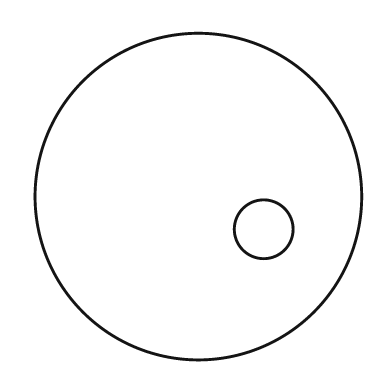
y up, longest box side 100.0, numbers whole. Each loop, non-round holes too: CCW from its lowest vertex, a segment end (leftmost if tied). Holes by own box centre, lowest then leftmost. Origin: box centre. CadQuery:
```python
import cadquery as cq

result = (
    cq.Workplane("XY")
    .moveTo(0.0, 0.0)
    .circle(50.0)
    .moveTo(20.0, -10.0)
    .circle(9.0)
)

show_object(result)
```